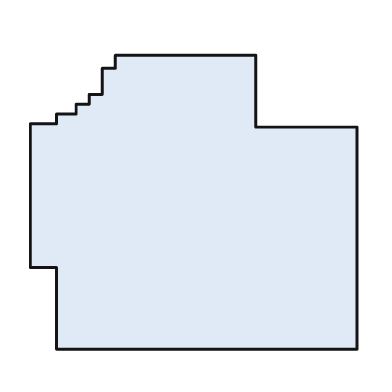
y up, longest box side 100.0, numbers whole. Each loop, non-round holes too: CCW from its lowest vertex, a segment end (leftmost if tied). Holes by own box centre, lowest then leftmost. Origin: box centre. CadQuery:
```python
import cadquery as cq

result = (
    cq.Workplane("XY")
    .moveTo(-42.0, -45.0)
    .lineTo(50.0, -45.0)
    .lineTo(50.0, 23.0)
    .lineTo(19.0, 23.0)
    .lineTo(19.0, 45.0)
    .lineTo(-24.0, 45.0)
    .lineTo(-24.0, 41.0)
    .lineTo(-28.0, 41.0)
    .lineTo(-28.0, 33.0)
    .lineTo(-32.0, 33.0)
    .lineTo(-32.0, 30.0)
    .lineTo(-36.0, 30.0)
    .lineTo(-36.0, 27.0)
    .lineTo(-42.0, 27.0)
    .lineTo(-42.0, 24.0)
    .lineTo(-50.0, 24.0)
    .lineTo(-50.0, -20.0)
    .lineTo(-42.0, -20.0)
    .close()
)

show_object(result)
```